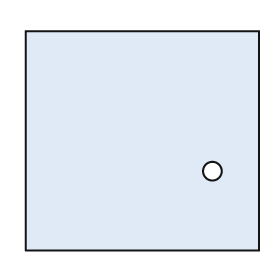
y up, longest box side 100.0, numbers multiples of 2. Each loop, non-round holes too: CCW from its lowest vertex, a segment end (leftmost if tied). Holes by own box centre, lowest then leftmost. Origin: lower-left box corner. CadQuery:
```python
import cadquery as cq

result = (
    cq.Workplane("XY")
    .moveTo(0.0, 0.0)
    .lineTo(100.0, 0.0)
    .lineTo(100.0, 94.0)
    .lineTo(0.0, 94.0)
    .close()
    .moveTo(80.0, 34.0)
    .circle(4.0)
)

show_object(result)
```